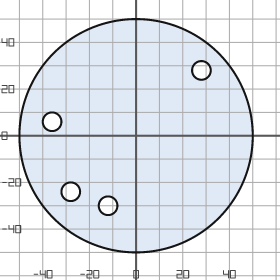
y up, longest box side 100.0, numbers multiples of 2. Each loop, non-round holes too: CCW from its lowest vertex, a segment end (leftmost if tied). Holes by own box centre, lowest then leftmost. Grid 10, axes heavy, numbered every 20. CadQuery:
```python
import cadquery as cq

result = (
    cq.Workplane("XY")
    .moveTo(0.0, 0.0)
    .circle(50.0)
    .moveTo(-12.0, -30.0)
    .circle(4.0)
    .moveTo(-28.0, -24.0)
    .circle(4.0)
    .moveTo(-36.0, 6.0)
    .circle(4.0)
    .moveTo(28.0, 28.0)
    .circle(4.0)
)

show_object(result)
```